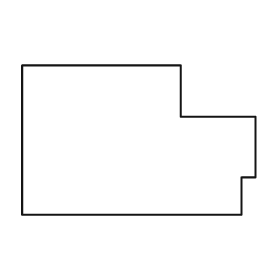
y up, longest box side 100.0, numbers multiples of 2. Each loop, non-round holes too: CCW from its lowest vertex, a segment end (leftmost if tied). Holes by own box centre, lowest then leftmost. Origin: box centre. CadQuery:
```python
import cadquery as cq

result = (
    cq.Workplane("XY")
    .moveTo(-50.0, -32.0)
    .lineTo(44.0, -32.0)
    .lineTo(44.0, -16.0)
    .lineTo(50.0, -16.0)
    .lineTo(50.0, 10.0)
    .lineTo(18.0, 10.0)
    .lineTo(18.0, 32.0)
    .lineTo(-50.0, 32.0)
    .close()
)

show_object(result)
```